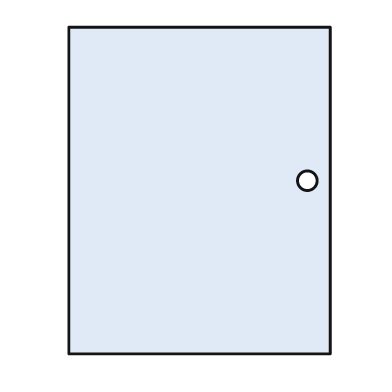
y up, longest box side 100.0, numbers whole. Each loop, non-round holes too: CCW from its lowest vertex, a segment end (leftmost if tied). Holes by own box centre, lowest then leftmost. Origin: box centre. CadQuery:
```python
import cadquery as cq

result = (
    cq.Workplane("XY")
    .moveTo(-40.0, -50.0)
    .lineTo(40.0, -50.0)
    .lineTo(40.0, 50.0)
    .lineTo(-40.0, 50.0)
    .close()
    .moveTo(33.0, 3.0)
    .circle(3.0)
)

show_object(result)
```